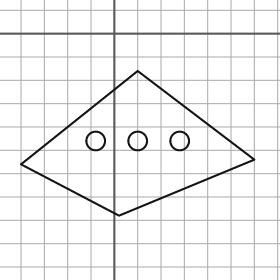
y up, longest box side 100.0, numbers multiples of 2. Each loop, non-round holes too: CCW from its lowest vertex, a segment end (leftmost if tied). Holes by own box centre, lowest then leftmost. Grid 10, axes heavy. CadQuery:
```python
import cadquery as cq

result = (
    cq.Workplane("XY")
    .moveTo(2.0, -78.0)
    .lineTo(60.0, -54.0)
    .lineTo(10.0, -16.0)
    .lineTo(-40.0, -56.0)
    .close()
    .moveTo(-8.0, -46.0)
    .circle(4.0)
    .moveTo(10.0, -46.0)
    .circle(4.0)
    .moveTo(28.0, -46.0)
    .circle(4.0)
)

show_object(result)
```